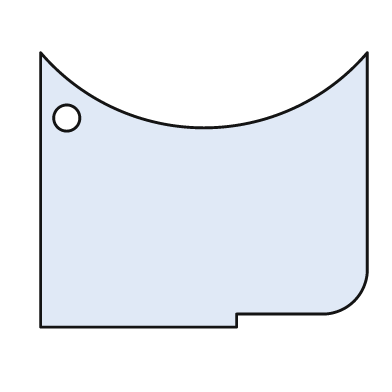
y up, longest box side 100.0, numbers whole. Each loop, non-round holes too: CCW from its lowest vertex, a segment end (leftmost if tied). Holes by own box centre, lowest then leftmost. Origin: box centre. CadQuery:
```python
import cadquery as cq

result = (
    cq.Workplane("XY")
    .moveTo(-50.0, -42.0)
    .lineTo(10.0, -42.0)
    .lineTo(10.0, -38.0)
    .lineTo(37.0, -38.0)
    .threePointArc((46.0, -34.0), (50.0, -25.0))
    .lineTo(50.0, 42.0)
    .threePointArc((0.0, 19.0), (-50.0, 42.0))
    .close()
    .moveTo(-42.0, 22.0)
    .circle(4.0)
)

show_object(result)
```